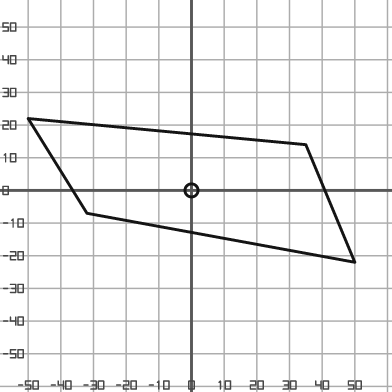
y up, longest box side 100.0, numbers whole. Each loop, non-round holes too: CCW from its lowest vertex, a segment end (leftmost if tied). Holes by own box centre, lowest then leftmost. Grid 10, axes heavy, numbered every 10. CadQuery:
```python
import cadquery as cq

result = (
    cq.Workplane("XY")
    .moveTo(50.0, -22.0)
    .lineTo(35.0, 14.0)
    .lineTo(-50.0, 22.0)
    .lineTo(-32.0, -7.0)
    .close()
    .moveTo(0.0, 0.0)
    .circle(2.0)
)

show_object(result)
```